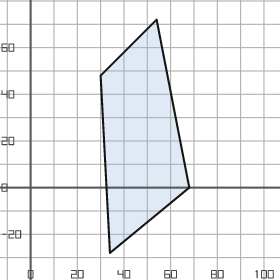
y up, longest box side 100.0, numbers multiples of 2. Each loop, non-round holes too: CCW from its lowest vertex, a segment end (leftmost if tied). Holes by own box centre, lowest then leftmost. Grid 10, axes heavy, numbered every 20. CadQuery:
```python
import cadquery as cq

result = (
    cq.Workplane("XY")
    .moveTo(34.0, -28.0)
    .lineTo(68.0, 0.0)
    .lineTo(54.0, 72.0)
    .lineTo(30.0, 48.0)
    .close()
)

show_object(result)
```